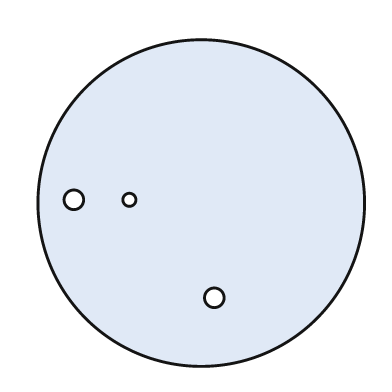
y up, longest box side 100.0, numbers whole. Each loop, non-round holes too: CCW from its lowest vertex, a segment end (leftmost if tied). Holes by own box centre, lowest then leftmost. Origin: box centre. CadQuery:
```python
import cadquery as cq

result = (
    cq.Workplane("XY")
    .moveTo(0.0, 0.0)
    .circle(50.0)
    .moveTo(4.0, -29.0)
    .circle(3.0)
    .moveTo(-39.0, 1.0)
    .circle(3.0)
    .moveTo(-22.0, 1.0)
    .circle(2.0)
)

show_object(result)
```